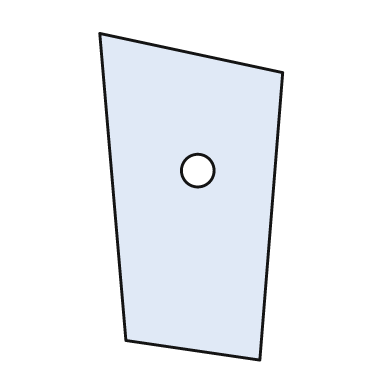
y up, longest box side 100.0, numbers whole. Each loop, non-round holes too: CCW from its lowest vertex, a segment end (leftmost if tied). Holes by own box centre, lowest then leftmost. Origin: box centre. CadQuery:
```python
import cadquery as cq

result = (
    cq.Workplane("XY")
    .moveTo(21.0, -50.0)
    .lineTo(28.0, 38.0)
    .lineTo(-28.0, 50.0)
    .lineTo(-20.0, -44.0)
    .close()
    .moveTo(2.0, 8.0)
    .circle(5.0)
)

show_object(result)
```